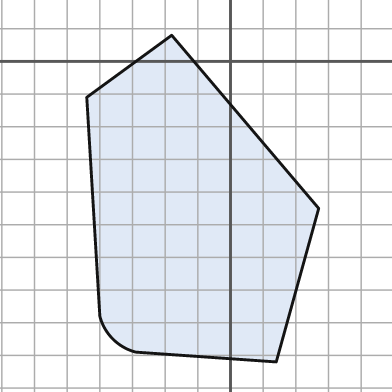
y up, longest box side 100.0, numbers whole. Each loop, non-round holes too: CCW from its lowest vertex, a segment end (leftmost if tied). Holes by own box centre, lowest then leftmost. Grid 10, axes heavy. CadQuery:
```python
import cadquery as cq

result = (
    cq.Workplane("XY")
    .moveTo(14.0, -92.0)
    .lineTo(27.0, -45.0)
    .lineTo(-18.0, 8.0)
    .lineTo(-44.0, -11.0)
    .lineTo(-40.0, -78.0)
    .threePointArc((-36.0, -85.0), (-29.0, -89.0))
    .close()
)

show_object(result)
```